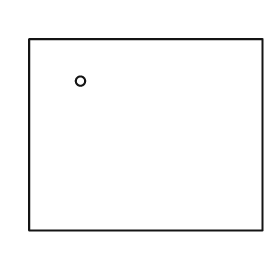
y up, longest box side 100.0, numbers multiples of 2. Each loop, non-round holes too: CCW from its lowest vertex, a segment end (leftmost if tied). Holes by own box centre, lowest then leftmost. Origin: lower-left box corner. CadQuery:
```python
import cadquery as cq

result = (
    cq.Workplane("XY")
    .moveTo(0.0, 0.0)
    .lineTo(100.0, 0.0)
    .lineTo(100.0, 82.0)
    .lineTo(0.0, 82.0)
    .close()
    .moveTo(22.0, 64.0)
    .circle(2.0)
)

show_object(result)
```